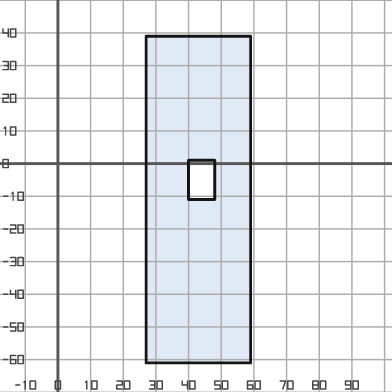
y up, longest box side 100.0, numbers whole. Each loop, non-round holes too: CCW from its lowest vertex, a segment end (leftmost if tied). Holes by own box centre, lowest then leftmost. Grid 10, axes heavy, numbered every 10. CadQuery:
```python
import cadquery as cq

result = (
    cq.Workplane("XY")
    .moveTo(27.0, -61.0)
    .lineTo(59.0, -61.0)
    .lineTo(59.0, 39.0)
    .lineTo(27.0, 39.0)
    .close()
    .moveTo(40.0, -11.0)
    .lineTo(48.0, -11.0)
    .lineTo(48.0, 1.0)
    .lineTo(40.0, 1.0)
    .close()
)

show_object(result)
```